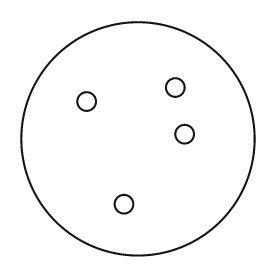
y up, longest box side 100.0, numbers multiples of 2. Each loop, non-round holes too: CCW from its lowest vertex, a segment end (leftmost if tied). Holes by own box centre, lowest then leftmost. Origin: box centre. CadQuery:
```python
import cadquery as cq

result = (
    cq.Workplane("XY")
    .moveTo(0.0, 0.0)
    .circle(50.0)
    .moveTo(-6.0, -28.0)
    .circle(4.0)
    .moveTo(20.0, 2.0)
    .circle(4.0)
    .moveTo(-22.0, 16.0)
    .circle(4.0)
    .moveTo(16.0, 22.0)
    .circle(4.0)
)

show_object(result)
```